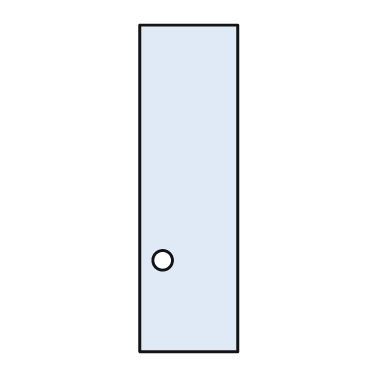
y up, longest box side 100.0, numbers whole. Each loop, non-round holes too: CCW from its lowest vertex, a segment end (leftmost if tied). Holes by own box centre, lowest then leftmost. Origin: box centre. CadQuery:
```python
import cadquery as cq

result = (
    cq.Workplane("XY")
    .moveTo(-15.0, -50.0)
    .lineTo(15.0, -50.0)
    .lineTo(15.0, 50.0)
    .lineTo(-15.0, 50.0)
    .close()
    .moveTo(-8.0, -22.0)
    .circle(3.0)
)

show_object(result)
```